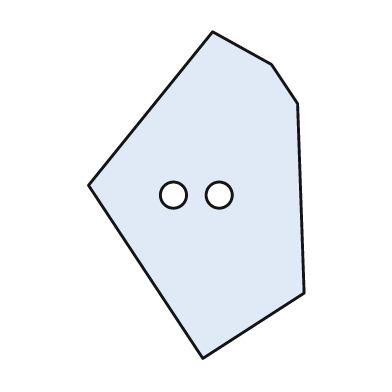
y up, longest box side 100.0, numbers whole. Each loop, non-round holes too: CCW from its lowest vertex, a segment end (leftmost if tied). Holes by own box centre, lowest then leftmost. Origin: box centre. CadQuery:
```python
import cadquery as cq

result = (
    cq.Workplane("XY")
    .moveTo(2.0, -50.0)
    .lineTo(33.0, -30.0)
    .lineTo(31.0, 28.0)
    .lineTo(23.0, 40.0)
    .lineTo(5.0, 50.0)
    .lineTo(-33.0, 3.0)
    .close()
    .moveTo(-7.0, 0.0)
    .circle(4.0)
    .moveTo(7.0, 0.0)
    .circle(4.0)
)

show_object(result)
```